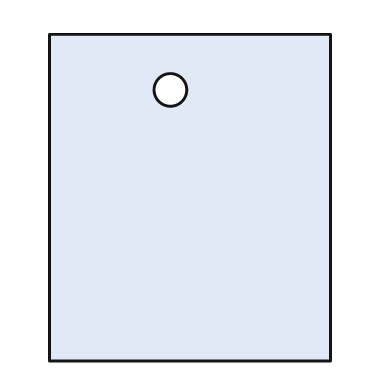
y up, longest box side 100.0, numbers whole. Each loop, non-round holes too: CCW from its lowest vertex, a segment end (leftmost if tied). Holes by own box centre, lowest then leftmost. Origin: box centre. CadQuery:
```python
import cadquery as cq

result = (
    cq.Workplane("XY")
    .moveTo(-43.0, -50.0)
    .lineTo(43.0, -50.0)
    .lineTo(43.0, 50.0)
    .lineTo(-43.0, 50.0)
    .close()
    .moveTo(-6.0, 33.0)
    .circle(5.0)
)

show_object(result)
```